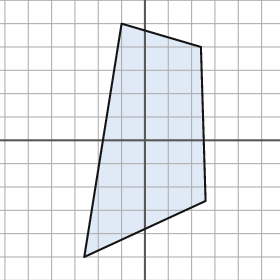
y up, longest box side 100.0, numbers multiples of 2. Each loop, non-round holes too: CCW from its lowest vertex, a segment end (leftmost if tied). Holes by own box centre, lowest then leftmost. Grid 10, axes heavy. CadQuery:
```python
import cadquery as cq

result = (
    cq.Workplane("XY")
    .moveTo(-26.0, -50.0)
    .lineTo(26.0, -26.0)
    .lineTo(24.0, 40.0)
    .lineTo(-10.0, 50.0)
    .close()
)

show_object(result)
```